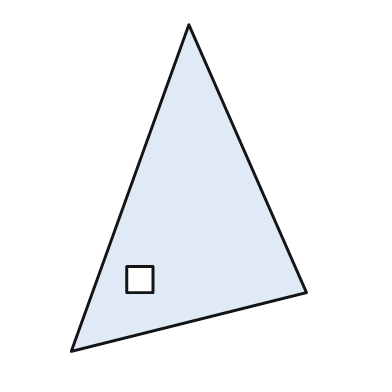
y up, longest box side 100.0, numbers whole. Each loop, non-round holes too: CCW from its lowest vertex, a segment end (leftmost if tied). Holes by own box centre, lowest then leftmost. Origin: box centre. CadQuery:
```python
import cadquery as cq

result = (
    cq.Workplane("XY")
    .moveTo(-36.0, -50.0)
    .lineTo(36.0, -32.0)
    .lineTo(0.0, 50.0)
    .close()
    .moveTo(-19.0, -32.0)
    .lineTo(-11.0, -32.0)
    .lineTo(-11.0, -24.0)
    .lineTo(-19.0, -24.0)
    .close()
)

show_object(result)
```